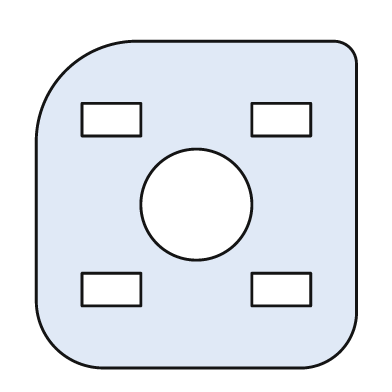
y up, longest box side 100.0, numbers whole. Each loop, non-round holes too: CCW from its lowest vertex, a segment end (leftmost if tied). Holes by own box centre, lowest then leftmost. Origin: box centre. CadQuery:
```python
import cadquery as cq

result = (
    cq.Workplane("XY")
    .moveTo(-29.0, -50.0)
    .lineTo(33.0, -50.0)
    .threePointArc((44.0, -45.0), (49.0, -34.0))
    .lineTo(49.0, 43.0)
    .threePointArc((47.0, 48.0), (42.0, 50.0))
    .lineTo(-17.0, 50.0)
    .threePointArc((-40.0, 41.0), (-49.0, 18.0))
    .lineTo(-49.0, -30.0)
    .threePointArc((-43.0, -44.0), (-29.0, -50.0))
    .close()
    .moveTo(-35.0, -31.0)
    .lineTo(-17.0, -31.0)
    .lineTo(-17.0, -21.0)
    .lineTo(-35.0, -21.0)
    .close()
    .moveTo(17.0, -31.0)
    .lineTo(35.0, -31.0)
    .lineTo(35.0, -21.0)
    .lineTo(17.0, -21.0)
    .close()
    .moveTo(0.0, 0.0)
    .circle(17.0)
    .moveTo(-35.0, 21.0)
    .lineTo(-17.0, 21.0)
    .lineTo(-17.0, 31.0)
    .lineTo(-35.0, 31.0)
    .close()
    .moveTo(17.0, 21.0)
    .lineTo(35.0, 21.0)
    .lineTo(35.0, 31.0)
    .lineTo(17.0, 31.0)
    .close()
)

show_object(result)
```